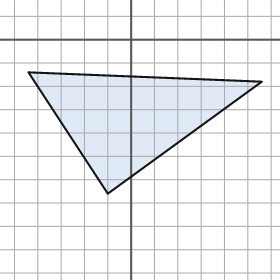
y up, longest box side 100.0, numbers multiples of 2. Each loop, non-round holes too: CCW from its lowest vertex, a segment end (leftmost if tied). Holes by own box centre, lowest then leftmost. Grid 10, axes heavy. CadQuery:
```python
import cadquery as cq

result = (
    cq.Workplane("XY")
    .moveTo(-10.0, -66.0)
    .lineTo(56.0, -18.0)
    .lineTo(-44.0, -14.0)
    .close()
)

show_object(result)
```